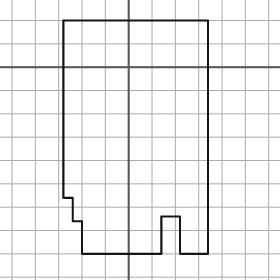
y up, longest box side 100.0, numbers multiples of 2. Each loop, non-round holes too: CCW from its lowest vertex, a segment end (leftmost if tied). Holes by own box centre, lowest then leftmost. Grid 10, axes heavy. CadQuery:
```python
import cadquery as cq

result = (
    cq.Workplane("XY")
    .moveTo(-20.0, -80.0)
    .lineTo(14.0, -80.0)
    .lineTo(14.0, -64.0)
    .lineTo(22.0, -64.0)
    .lineTo(22.0, -80.0)
    .lineTo(34.0, -80.0)
    .lineTo(34.0, 20.0)
    .lineTo(-28.0, 20.0)
    .lineTo(-28.0, -56.0)
    .lineTo(-24.0, -56.0)
    .lineTo(-24.0, -66.0)
    .lineTo(-20.0, -66.0)
    .close()
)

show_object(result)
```